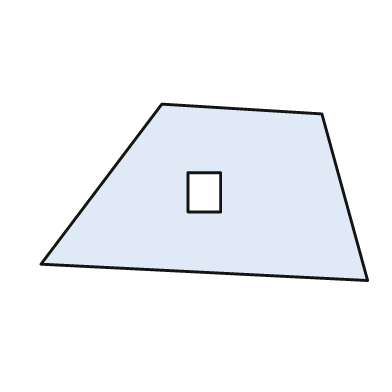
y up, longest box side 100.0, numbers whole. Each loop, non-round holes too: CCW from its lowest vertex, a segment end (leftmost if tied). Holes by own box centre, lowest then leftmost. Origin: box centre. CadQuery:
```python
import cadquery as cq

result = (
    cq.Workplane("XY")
    .moveTo(50.0, -27.0)
    .lineTo(36.0, 24.0)
    .lineTo(-13.0, 27.0)
    .lineTo(-50.0, -22.0)
    .close()
    .moveTo(-5.0, -6.0)
    .lineTo(5.0, -6.0)
    .lineTo(5.0, 6.0)
    .lineTo(-5.0, 6.0)
    .close()
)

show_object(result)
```